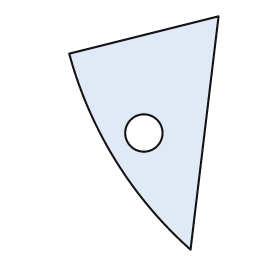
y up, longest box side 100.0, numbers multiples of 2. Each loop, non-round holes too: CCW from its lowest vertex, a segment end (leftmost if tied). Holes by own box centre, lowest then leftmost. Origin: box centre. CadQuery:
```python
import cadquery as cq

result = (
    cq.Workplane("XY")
    .moveTo(20.0, -50.0)
    .lineTo(32.0, 50.0)
    .lineTo(-32.0, 34.0)
    .threePointArc((-12.0, -12.0), (20.0, -50.0))
    .close()
    .moveTo(0.0, 0.0)
    .circle(8.0)
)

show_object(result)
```